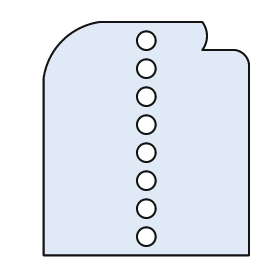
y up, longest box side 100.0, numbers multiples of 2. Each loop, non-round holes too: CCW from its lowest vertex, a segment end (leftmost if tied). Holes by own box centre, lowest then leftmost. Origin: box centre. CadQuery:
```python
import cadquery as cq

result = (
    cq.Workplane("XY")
    .moveTo(-44.0, -50.0)
    .lineTo(44.0, -50.0)
    .lineTo(44.0, 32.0)
    .threePointArc((42.0, 36.0), (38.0, 38.0))
    .lineTo(24.0, 38.0)
    .threePointArc((26.0, 44.0), (24.0, 50.0))
    .lineTo(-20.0, 50.0)
    .threePointArc((-36.0, 42.0), (-44.0, 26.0))
    .close()
    .moveTo(0.0, -42.0)
    .circle(4.0)
    .moveTo(0.0, -30.0)
    .circle(4.0)
    .moveTo(0.0, -18.0)
    .circle(4.0)
    .moveTo(0.0, -6.0)
    .circle(4.0)
    .moveTo(0.0, 6.0)
    .circle(4.0)
    .moveTo(0.0, 18.0)
    .circle(4.0)
    .moveTo(0.0, 30.0)
    .circle(4.0)
    .moveTo(0.0, 42.0)
    .circle(4.0)
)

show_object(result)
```